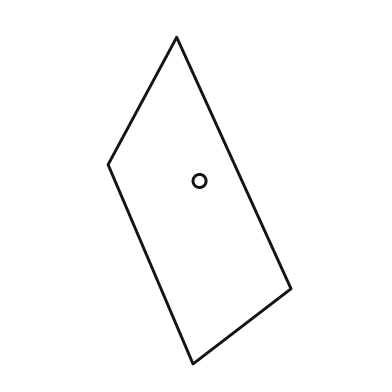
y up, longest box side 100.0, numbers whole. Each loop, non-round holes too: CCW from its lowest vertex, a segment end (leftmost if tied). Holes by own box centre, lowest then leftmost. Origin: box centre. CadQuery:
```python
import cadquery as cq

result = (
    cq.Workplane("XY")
    .moveTo(-2.0, -50.0)
    .lineTo(28.0, -27.0)
    .lineTo(-7.0, 50.0)
    .lineTo(-28.0, 11.0)
    .close()
    .moveTo(0.0, 6.0)
    .circle(2.0)
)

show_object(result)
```